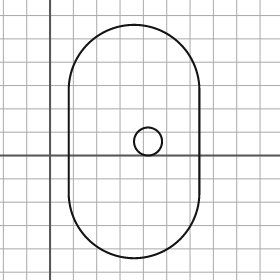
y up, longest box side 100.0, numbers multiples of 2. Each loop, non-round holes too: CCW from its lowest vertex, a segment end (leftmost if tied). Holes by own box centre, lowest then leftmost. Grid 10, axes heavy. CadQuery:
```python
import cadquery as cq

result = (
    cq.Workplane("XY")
    .moveTo(8.0, -16.0)
    .threePointArc((36.0, -44.0), (64.0, -16.0))
    .lineTo(64.0, 28.0)
    .threePointArc((36.0, 56.0), (8.0, 28.0))
    .close()
    .moveTo(42.0, 6.0)
    .circle(6.0)
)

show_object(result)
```